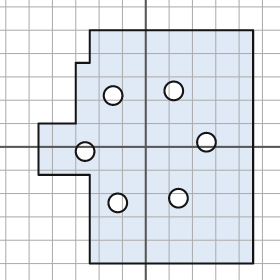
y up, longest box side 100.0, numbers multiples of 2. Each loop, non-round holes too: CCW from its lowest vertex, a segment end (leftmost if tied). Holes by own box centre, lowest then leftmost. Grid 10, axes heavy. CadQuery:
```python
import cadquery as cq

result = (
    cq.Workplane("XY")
    .moveTo(-24.0, -50.0)
    .lineTo(46.0, -50.0)
    .lineTo(46.0, 50.0)
    .lineTo(-24.0, 50.0)
    .lineTo(-24.0, 36.0)
    .lineTo(-30.0, 36.0)
    .lineTo(-30.0, 10.0)
    .lineTo(-46.0, 10.0)
    .lineTo(-46.0, -12.0)
    .lineTo(-24.0, -12.0)
    .close()
    .moveTo(-12.0, -24.0)
    .circle(4.0)
    .moveTo(14.0, -22.0)
    .circle(4.0)
    .moveTo(-26.0, -2.0)
    .circle(4.0)
    .moveTo(26.0, 2.0)
    .circle(4.0)
    .moveTo(-14.0, 22.0)
    .circle(4.0)
    .moveTo(12.0, 24.0)
    .circle(4.0)
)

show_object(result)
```